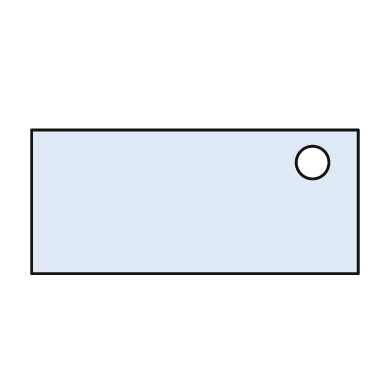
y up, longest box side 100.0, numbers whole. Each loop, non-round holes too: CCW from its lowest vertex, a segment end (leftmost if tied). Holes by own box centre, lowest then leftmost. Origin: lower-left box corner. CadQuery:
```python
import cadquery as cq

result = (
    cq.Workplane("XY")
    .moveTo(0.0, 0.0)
    .lineTo(100.0, 0.0)
    .lineTo(100.0, 44.0)
    .lineTo(0.0, 44.0)
    .close()
    .moveTo(86.0, 34.0)
    .circle(5.0)
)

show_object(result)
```